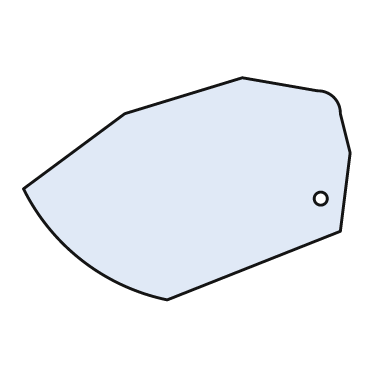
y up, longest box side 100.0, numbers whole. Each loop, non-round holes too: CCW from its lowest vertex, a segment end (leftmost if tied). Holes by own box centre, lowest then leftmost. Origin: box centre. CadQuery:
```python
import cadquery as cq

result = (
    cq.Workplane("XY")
    .moveTo(-6.0, -34.0)
    .lineTo(47.0, -13.0)
    .lineTo(50.0, 11.0)
    .lineTo(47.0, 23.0)
    .threePointArc((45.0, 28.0), (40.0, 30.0))
    .lineTo(17.0, 34.0)
    .lineTo(-19.0, 23.0)
    .lineTo(-50.0, 0.0)
    .threePointArc((-32.0, -22.0), (-6.0, -34.0))
    .close()
    .moveTo(41.0, -3.0)
    .circle(2.0)
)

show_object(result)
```